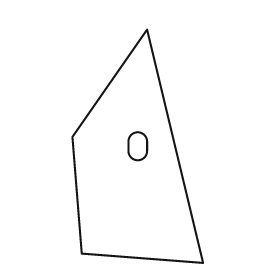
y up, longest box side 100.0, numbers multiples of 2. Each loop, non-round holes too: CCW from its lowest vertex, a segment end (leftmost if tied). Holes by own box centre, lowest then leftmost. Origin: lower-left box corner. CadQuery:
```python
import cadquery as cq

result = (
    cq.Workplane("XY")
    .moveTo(56.0, 0.0)
    .lineTo(32.0, 100.0)
    .lineTo(0.0, 54.0)
    .lineTo(4.0, 4.0)
    .close()
    .moveTo(24.0, 48.0)
    .threePointArc((28.0, 44.0), (32.0, 48.0))
    .lineTo(32.0, 52.0)
    .threePointArc((28.0, 56.0), (24.0, 52.0))
    .close()
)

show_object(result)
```